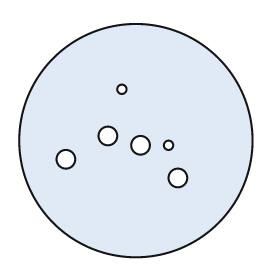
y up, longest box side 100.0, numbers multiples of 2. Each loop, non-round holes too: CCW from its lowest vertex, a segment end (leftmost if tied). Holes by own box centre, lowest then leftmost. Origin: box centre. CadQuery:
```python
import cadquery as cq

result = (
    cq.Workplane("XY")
    .moveTo(0.0, 0.0)
    .circle(50.0)
    .moveTo(18.0, -16.0)
    .circle(4.0)
    .moveTo(-30.0, -8.0)
    .circle(4.0)
    .moveTo(2.0, -2.0)
    .circle(4.0)
    .moveTo(14.0, -2.0)
    .circle(2.0)
    .moveTo(-12.0, 2.0)
    .circle(4.0)
    .moveTo(-6.0, 22.0)
    .circle(2.0)
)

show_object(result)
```